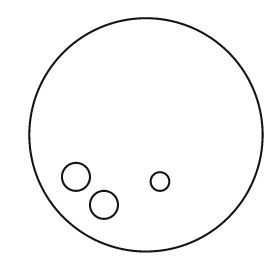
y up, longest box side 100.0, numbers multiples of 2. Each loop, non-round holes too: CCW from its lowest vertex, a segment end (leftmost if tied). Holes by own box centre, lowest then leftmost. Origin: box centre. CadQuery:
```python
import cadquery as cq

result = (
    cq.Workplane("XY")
    .moveTo(0.0, 0.0)
    .circle(50.0)
    .moveTo(-18.0, -30.0)
    .circle(6.0)
    .moveTo(6.0, -20.0)
    .circle(4.0)
    .moveTo(-30.0, -18.0)
    .circle(6.0)
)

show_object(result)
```